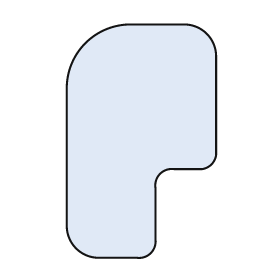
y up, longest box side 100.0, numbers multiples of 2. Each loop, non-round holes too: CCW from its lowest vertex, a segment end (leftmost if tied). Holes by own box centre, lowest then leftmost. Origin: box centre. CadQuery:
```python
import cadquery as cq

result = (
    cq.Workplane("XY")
    .moveTo(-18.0, -50.0)
    .lineTo(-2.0, -50.0)
    .threePointArc((4.0, -48.0), (6.0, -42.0))
    .lineTo(6.0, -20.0)
    .threePointArc((8.0, -14.0), (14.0, -12.0))
    .lineTo(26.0, -12.0)
    .threePointArc((30.0, -10.0), (32.0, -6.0))
    .lineTo(32.0, 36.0)
    .threePointArc((28.0, 46.0), (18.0, 50.0))
    .lineTo(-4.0, 50.0)
    .threePointArc((-24.0, 42.0), (-32.0, 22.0))
    .lineTo(-32.0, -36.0)
    .threePointArc((-28.0, -46.0), (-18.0, -50.0))
    .close()
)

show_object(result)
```